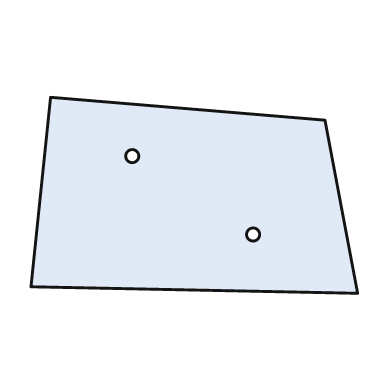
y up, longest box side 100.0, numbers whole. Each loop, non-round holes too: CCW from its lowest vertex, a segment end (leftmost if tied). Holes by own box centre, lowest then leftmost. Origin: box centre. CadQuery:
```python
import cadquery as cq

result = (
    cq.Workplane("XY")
    .moveTo(50.0, -30.0)
    .lineTo(40.0, 23.0)
    .lineTo(-44.0, 30.0)
    .lineTo(-50.0, -28.0)
    .close()
    .moveTo(18.0, -12.0)
    .circle(2.0)
    .moveTo(-19.0, 12.0)
    .circle(2.0)
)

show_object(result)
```